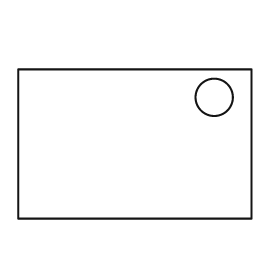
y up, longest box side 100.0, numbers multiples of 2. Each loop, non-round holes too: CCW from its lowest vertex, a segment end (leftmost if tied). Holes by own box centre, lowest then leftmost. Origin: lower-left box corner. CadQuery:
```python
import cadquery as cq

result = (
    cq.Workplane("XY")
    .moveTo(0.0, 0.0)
    .lineTo(100.0, 0.0)
    .lineTo(100.0, 64.0)
    .lineTo(0.0, 64.0)
    .close()
    .moveTo(84.0, 52.0)
    .circle(8.0)
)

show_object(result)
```